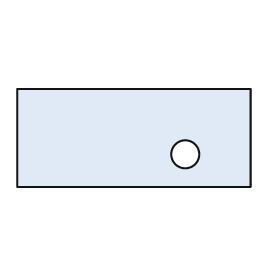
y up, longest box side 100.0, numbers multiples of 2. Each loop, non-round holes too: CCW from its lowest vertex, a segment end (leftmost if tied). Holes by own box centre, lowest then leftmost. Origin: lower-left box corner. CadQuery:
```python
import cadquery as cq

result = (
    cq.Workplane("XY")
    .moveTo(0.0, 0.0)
    .lineTo(100.0, 0.0)
    .lineTo(100.0, 42.0)
    .lineTo(0.0, 42.0)
    .close()
    .moveTo(72.0, 14.0)
    .circle(6.0)
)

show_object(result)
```